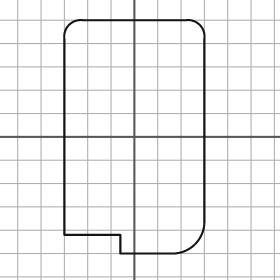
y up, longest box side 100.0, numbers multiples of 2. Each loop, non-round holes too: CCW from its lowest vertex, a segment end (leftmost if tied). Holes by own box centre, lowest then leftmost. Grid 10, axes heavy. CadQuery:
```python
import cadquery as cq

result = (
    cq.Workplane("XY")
    .moveTo(-6.0, -50.0)
    .lineTo(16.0, -50.0)
    .threePointArc((26.0, -46.0), (30.0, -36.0))
    .lineTo(30.0, 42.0)
    .threePointArc((28.0, 48.0), (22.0, 50.0))
    .lineTo(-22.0, 50.0)
    .threePointArc((-28.0, 48.0), (-30.0, 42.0))
    .lineTo(-30.0, -42.0)
    .lineTo(-6.0, -42.0)
    .close()
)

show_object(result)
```